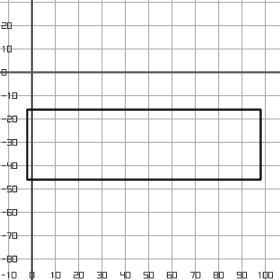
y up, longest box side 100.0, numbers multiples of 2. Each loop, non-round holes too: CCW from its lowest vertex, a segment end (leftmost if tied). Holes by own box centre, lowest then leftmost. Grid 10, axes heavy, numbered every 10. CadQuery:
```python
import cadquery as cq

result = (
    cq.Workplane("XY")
    .moveTo(-2.0, -46.0)
    .lineTo(98.0, -46.0)
    .lineTo(98.0, -16.0)
    .lineTo(-2.0, -16.0)
    .close()
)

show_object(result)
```